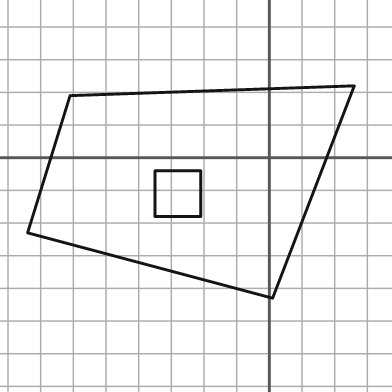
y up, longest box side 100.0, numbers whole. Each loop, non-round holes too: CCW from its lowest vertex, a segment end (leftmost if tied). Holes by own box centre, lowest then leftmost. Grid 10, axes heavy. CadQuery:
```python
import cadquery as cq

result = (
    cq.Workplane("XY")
    .moveTo(1.0, -43.0)
    .lineTo(26.0, 22.0)
    .lineTo(-61.0, 19.0)
    .lineTo(-74.0, -23.0)
    .close()
    .moveTo(-35.0, -18.0)
    .lineTo(-21.0, -18.0)
    .lineTo(-21.0, -4.0)
    .lineTo(-35.0, -4.0)
    .close()
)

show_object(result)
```